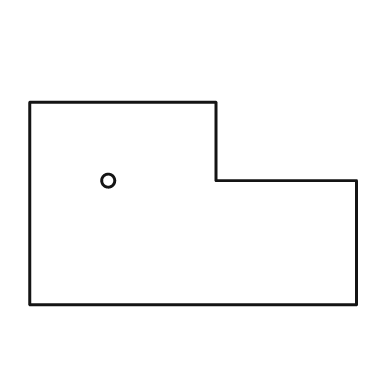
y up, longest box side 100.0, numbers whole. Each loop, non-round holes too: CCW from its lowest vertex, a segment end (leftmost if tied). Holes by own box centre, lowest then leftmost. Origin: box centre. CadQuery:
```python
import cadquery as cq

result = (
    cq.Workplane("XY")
    .moveTo(-50.0, -31.0)
    .lineTo(50.0, -31.0)
    .lineTo(50.0, 7.0)
    .lineTo(7.0, 7.0)
    .lineTo(7.0, 31.0)
    .lineTo(-50.0, 31.0)
    .close()
    .moveTo(-26.0, 7.0)
    .circle(2.0)
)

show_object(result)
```